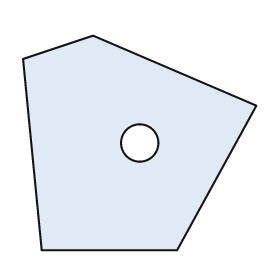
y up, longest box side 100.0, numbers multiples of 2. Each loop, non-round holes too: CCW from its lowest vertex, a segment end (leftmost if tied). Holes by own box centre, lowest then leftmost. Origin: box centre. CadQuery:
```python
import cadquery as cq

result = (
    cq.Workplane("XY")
    .moveTo(-42.0, -46.0)
    .lineTo(16.0, -46.0)
    .lineTo(50.0, 16.0)
    .lineTo(-20.0, 46.0)
    .lineTo(-50.0, 36.0)
    .close()
    .moveTo(0.0, 0.0)
    .circle(8.0)
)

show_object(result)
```